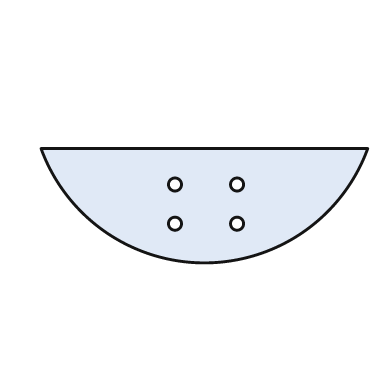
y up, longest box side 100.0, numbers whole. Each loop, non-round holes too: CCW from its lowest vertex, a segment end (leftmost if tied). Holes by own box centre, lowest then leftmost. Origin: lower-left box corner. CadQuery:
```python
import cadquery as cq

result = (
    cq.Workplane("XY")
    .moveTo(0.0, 35.0)
    .threePointArc((50.0, 0.0), (100.0, 35.0))
    .close()
    .moveTo(41.0, 12.0)
    .circle(2.0)
    .moveTo(60.0, 12.0)
    .circle(2.0)
    .moveTo(41.0, 24.0)
    .circle(2.0)
    .moveTo(60.0, 24.0)
    .circle(2.0)
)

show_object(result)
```